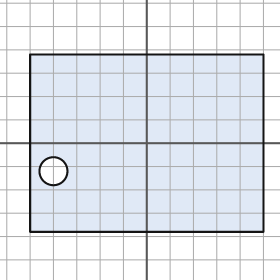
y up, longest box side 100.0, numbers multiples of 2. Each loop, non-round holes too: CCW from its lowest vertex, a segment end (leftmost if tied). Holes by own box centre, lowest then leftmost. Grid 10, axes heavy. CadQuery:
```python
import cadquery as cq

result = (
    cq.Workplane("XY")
    .moveTo(-50.0, -38.0)
    .lineTo(50.0, -38.0)
    .lineTo(50.0, 38.0)
    .lineTo(-50.0, 38.0)
    .close()
    .moveTo(-40.0, -12.0)
    .circle(6.0)
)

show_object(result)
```